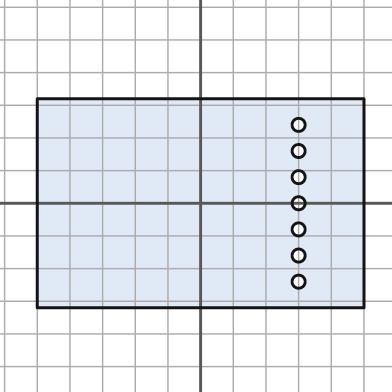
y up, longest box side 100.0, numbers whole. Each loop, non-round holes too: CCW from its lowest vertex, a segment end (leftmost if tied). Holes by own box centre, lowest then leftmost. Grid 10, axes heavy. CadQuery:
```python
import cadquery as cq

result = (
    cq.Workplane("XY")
    .moveTo(-50.0, -32.0)
    .lineTo(50.0, -32.0)
    .lineTo(50.0, 32.0)
    .lineTo(-50.0, 32.0)
    .close()
    .moveTo(30.0, -24.0)
    .circle(2.0)
    .moveTo(30.0, -16.0)
    .circle(2.0)
    .moveTo(30.0, -8.0)
    .circle(2.0)
    .moveTo(30.0, 0.0)
    .circle(2.0)
    .moveTo(30.0, 8.0)
    .circle(2.0)
    .moveTo(30.0, 16.0)
    .circle(2.0)
    .moveTo(30.0, 24.0)
    .circle(2.0)
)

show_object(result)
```